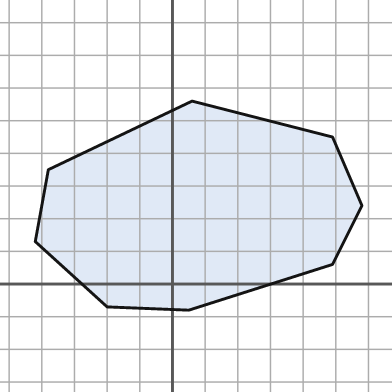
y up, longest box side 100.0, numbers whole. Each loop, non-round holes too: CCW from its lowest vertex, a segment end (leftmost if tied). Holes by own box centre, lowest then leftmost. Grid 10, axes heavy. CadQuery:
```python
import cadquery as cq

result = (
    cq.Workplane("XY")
    .moveTo(5.0, -8.0)
    .lineTo(49.0, 6.0)
    .lineTo(58.0, 24.0)
    .lineTo(49.0, 45.0)
    .lineTo(6.0, 56.0)
    .lineTo(-38.0, 35.0)
    .lineTo(-42.0, 13.0)
    .lineTo(-20.0, -7.0)
    .close()
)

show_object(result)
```